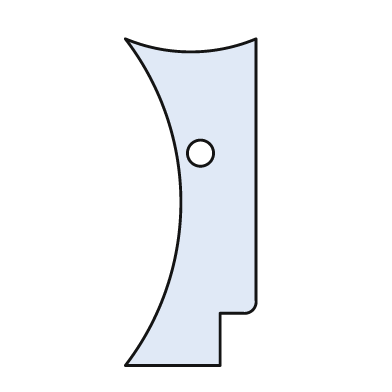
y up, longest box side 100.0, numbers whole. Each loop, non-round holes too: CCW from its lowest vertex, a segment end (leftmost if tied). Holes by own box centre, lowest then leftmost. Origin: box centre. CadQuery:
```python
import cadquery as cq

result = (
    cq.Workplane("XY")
    .moveTo(-20.0, -50.0)
    .lineTo(9.0, -50.0)
    .lineTo(9.0, -34.0)
    .lineTo(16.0, -34.0)
    .threePointArc((19.0, -33.0), (20.0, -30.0))
    .lineTo(20.0, 50.0)
    .threePointArc((0.0, 46.0), (-20.0, 50.0))
    .threePointArc((-3.0, 0.0), (-20.0, -50.0))
    .close()
    .moveTo(3.0, 15.0)
    .circle(4.0)
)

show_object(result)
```